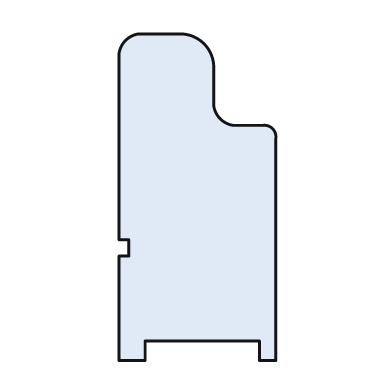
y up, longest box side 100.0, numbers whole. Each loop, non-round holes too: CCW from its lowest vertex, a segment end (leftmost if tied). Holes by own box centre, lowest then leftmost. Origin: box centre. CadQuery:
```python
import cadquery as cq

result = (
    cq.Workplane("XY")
    .moveTo(-24.0, -50.0)
    .lineTo(-16.0, -50.0)
    .lineTo(-16.0, -44.0)
    .lineTo(19.0, -44.0)
    .lineTo(19.0, -50.0)
    .lineTo(24.0, -50.0)
    .lineTo(24.0, 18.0)
    .threePointArc((23.0, 21.0), (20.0, 22.0))
    .lineTo(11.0, 22.0)
    .threePointArc((7.0, 24.0), (5.0, 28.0))
    .lineTo(5.0, 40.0)
    .threePointArc((2.0, 47.0), (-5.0, 50.0))
    .lineTo(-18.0, 50.0)
    .threePointArc((-22.0, 48.0), (-24.0, 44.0))
    .lineTo(-24.0, -13.0)
    .lineTo(-21.0, -13.0)
    .lineTo(-21.0, -18.0)
    .lineTo(-24.0, -18.0)
    .close()
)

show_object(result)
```